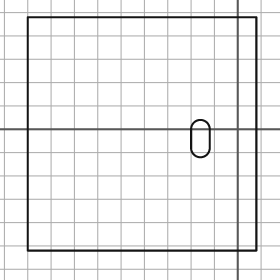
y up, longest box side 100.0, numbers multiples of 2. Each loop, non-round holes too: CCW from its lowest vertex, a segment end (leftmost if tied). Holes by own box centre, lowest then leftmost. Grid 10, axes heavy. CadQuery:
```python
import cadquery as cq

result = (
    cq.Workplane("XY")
    .moveTo(-90.0, -52.0)
    .lineTo(8.0, -52.0)
    .lineTo(8.0, 48.0)
    .lineTo(-90.0, 48.0)
    .close()
    .moveTo(-20.0, -8.0)
    .threePointArc((-16.0, -12.0), (-12.0, -8.0))
    .lineTo(-12.0, 0.0)
    .threePointArc((-16.0, 4.0), (-20.0, 0.0))
    .close()
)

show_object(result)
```